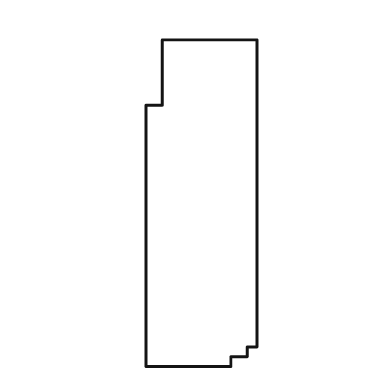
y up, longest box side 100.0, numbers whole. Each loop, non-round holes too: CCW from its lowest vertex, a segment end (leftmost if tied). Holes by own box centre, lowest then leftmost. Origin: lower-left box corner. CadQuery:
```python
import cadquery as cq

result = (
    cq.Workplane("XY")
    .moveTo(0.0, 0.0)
    .lineTo(26.0, 0.0)
    .lineTo(26.0, 3.0)
    .lineTo(31.0, 3.0)
    .lineTo(31.0, 6.0)
    .lineTo(34.0, 6.0)
    .lineTo(34.0, 100.0)
    .lineTo(5.0, 100.0)
    .lineTo(5.0, 80.0)
    .lineTo(0.0, 80.0)
    .close()
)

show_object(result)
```